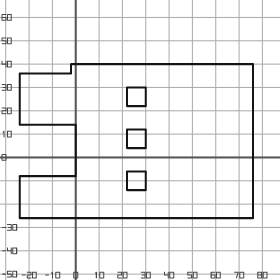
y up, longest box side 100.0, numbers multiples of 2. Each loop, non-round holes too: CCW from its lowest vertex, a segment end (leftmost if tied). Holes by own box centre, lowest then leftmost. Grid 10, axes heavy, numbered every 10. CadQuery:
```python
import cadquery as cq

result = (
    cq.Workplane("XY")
    .moveTo(-24.0, -26.0)
    .lineTo(76.0, -26.0)
    .lineTo(76.0, 40.0)
    .lineTo(-2.0, 40.0)
    .lineTo(-2.0, 36.0)
    .lineTo(-24.0, 36.0)
    .lineTo(-24.0, 14.0)
    .lineTo(0.0, 14.0)
    .lineTo(0.0, -8.0)
    .lineTo(-24.0, -8.0)
    .close()
    .moveTo(22.0, -14.0)
    .lineTo(30.0, -14.0)
    .lineTo(30.0, -6.0)
    .lineTo(22.0, -6.0)
    .close()
    .moveTo(22.0, 4.0)
    .lineTo(30.0, 4.0)
    .lineTo(30.0, 12.0)
    .lineTo(22.0, 12.0)
    .close()
    .moveTo(22.0, 22.0)
    .lineTo(30.0, 22.0)
    .lineTo(30.0, 30.0)
    .lineTo(22.0, 30.0)
    .close()
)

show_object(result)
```